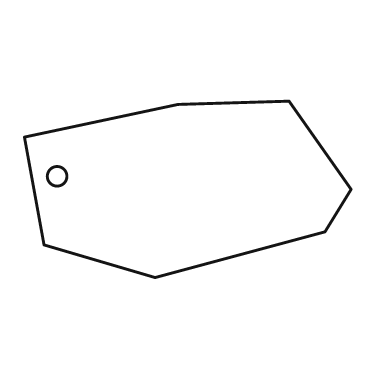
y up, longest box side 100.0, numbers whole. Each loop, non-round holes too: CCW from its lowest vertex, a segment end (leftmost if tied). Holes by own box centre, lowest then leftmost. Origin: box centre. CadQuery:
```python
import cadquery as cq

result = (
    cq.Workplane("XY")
    .moveTo(-10.0, -27.0)
    .lineTo(42.0, -13.0)
    .lineTo(50.0, 0.0)
    .lineTo(31.0, 27.0)
    .lineTo(-3.0, 26.0)
    .lineTo(-50.0, 16.0)
    .lineTo(-44.0, -17.0)
    .close()
    .moveTo(-40.0, 4.0)
    .circle(3.0)
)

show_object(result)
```